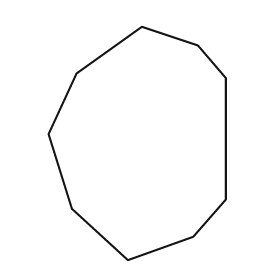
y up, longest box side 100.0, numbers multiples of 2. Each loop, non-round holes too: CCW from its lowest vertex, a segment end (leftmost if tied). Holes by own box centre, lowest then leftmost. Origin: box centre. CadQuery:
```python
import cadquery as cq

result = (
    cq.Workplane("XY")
    .moveTo(-4.0, -50.0)
    .lineTo(24.0, -40.0)
    .lineTo(38.0, -24.0)
    .lineTo(38.0, 28.0)
    .lineTo(26.0, 42.0)
    .lineTo(2.0, 50.0)
    .lineTo(-26.0, 30.0)
    .lineTo(-38.0, 4.0)
    .lineTo(-28.0, -28.0)
    .close()
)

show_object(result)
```